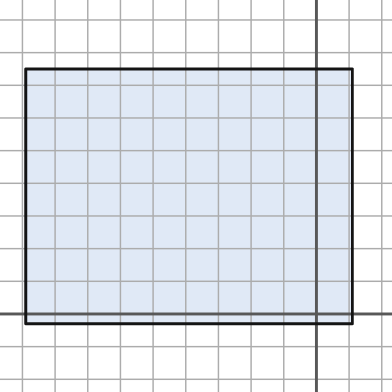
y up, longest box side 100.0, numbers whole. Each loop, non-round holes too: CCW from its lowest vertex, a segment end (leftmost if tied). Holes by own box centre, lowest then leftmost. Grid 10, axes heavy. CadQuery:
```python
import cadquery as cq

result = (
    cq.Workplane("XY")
    .moveTo(-89.0, -3.0)
    .lineTo(11.0, -3.0)
    .lineTo(11.0, 75.0)
    .lineTo(-89.0, 75.0)
    .close()
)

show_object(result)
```